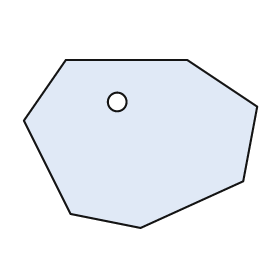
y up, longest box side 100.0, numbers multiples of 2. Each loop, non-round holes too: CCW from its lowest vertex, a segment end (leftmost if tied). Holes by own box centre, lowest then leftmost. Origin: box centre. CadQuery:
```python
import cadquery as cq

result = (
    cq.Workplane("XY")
    .moveTo(0.0, -36.0)
    .lineTo(44.0, -16.0)
    .lineTo(50.0, 16.0)
    .lineTo(20.0, 36.0)
    .lineTo(-32.0, 36.0)
    .lineTo(-50.0, 10.0)
    .lineTo(-30.0, -30.0)
    .close()
    .moveTo(-10.0, 18.0)
    .circle(4.0)
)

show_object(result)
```